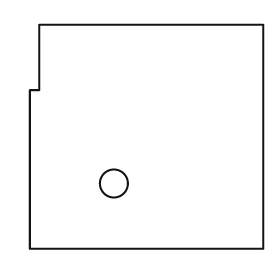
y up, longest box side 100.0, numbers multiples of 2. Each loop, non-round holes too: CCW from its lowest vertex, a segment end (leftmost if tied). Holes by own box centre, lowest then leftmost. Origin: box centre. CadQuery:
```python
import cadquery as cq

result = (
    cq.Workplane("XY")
    .moveTo(-50.0, -48.0)
    .lineTo(50.0, -48.0)
    .lineTo(50.0, 48.0)
    .lineTo(-46.0, 48.0)
    .lineTo(-46.0, 20.0)
    .lineTo(-50.0, 20.0)
    .close()
    .moveTo(-14.0, -20.0)
    .circle(6.0)
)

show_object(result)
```